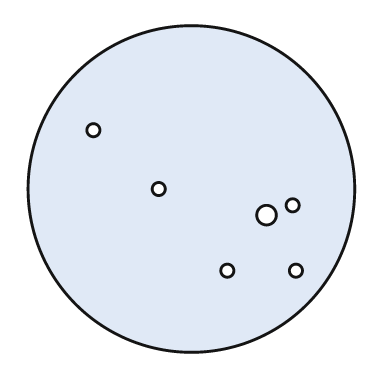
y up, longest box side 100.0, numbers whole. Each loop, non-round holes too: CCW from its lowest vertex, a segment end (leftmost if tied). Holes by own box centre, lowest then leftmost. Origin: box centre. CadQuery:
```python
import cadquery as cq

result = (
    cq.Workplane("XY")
    .moveTo(0.0, 0.0)
    .circle(50.0)
    .moveTo(11.0, -25.0)
    .circle(2.0)
    .moveTo(32.0, -25.0)
    .circle(2.0)
    .moveTo(23.0, -8.0)
    .circle(3.0)
    .moveTo(31.0, -5.0)
    .circle(2.0)
    .moveTo(-10.0, 0.0)
    .circle(2.0)
    .moveTo(-30.0, 18.0)
    .circle(2.0)
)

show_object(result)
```